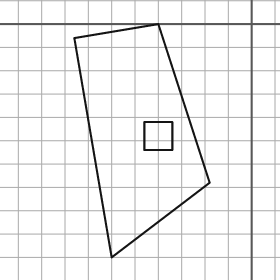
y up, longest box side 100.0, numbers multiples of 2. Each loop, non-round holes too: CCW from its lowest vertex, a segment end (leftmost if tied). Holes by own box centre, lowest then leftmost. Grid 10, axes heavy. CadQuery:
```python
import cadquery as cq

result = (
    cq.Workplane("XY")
    .moveTo(-60.0, -100.0)
    .lineTo(-18.0, -68.0)
    .lineTo(-40.0, 0.0)
    .lineTo(-76.0, -6.0)
    .close()
    .moveTo(-46.0, -54.0)
    .lineTo(-34.0, -54.0)
    .lineTo(-34.0, -42.0)
    .lineTo(-46.0, -42.0)
    .close()
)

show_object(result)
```